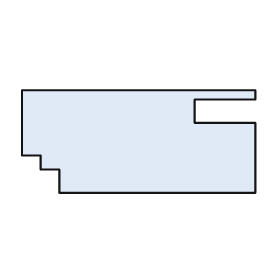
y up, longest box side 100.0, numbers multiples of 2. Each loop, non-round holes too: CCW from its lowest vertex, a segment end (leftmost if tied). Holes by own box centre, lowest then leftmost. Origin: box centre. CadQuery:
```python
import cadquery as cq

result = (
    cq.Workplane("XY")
    .moveTo(-34.0, -22.0)
    .lineTo(50.0, -22.0)
    .lineTo(50.0, 8.0)
    .lineTo(24.0, 8.0)
    .lineTo(24.0, 18.0)
    .lineTo(50.0, 18.0)
    .lineTo(50.0, 22.0)
    .lineTo(-50.0, 22.0)
    .lineTo(-50.0, -6.0)
    .lineTo(-42.0, -6.0)
    .lineTo(-42.0, -12.0)
    .lineTo(-34.0, -12.0)
    .close()
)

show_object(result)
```